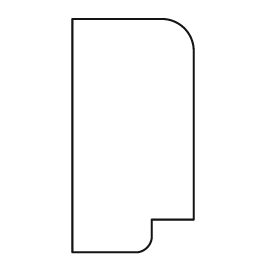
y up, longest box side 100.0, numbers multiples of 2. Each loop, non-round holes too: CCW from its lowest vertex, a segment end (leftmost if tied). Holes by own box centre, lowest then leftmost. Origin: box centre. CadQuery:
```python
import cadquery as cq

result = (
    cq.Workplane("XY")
    .moveTo(-26.0, -50.0)
    .lineTo(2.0, -50.0)
    .threePointArc((6.0, -48.0), (8.0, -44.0))
    .lineTo(8.0, -36.0)
    .lineTo(26.0, -36.0)
    .lineTo(26.0, 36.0)
    .threePointArc((22.0, 46.0), (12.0, 50.0))
    .lineTo(-26.0, 50.0)
    .close()
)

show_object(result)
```